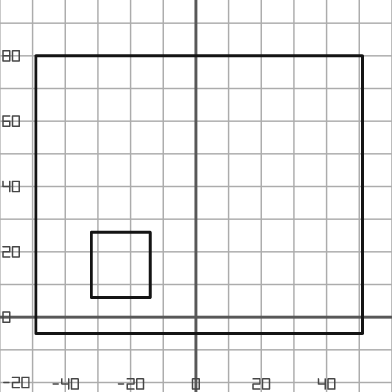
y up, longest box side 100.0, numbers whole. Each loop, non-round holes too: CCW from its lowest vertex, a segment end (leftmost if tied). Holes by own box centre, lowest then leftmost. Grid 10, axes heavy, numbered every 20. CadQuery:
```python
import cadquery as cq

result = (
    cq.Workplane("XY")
    .moveTo(-49.0, -5.0)
    .lineTo(51.0, -5.0)
    .lineTo(51.0, 80.0)
    .lineTo(-49.0, 80.0)
    .close()
    .moveTo(-32.0, 6.0)
    .lineTo(-14.0, 6.0)
    .lineTo(-14.0, 26.0)
    .lineTo(-32.0, 26.0)
    .close()
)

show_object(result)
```